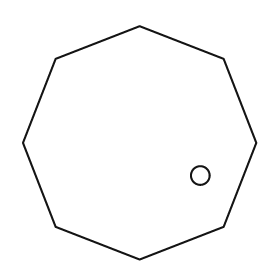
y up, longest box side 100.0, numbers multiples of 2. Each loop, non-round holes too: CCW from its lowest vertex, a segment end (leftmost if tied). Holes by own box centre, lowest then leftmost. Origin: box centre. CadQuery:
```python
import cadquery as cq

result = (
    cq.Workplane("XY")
    .moveTo(0.0, -50.0)
    .lineTo(36.0, -36.0)
    .lineTo(50.0, 0.0)
    .lineTo(36.0, 36.0)
    .lineTo(0.0, 50.0)
    .lineTo(-36.0, 36.0)
    .lineTo(-50.0, 0.0)
    .lineTo(-36.0, -36.0)
    .close()
    .moveTo(26.0, -14.0)
    .circle(4.0)
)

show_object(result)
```